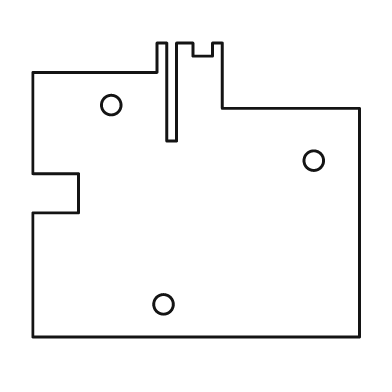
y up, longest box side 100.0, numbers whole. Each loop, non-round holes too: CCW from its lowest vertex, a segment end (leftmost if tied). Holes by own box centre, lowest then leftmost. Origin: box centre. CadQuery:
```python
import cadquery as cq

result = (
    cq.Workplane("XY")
    .moveTo(-50.0, -45.0)
    .lineTo(50.0, -45.0)
    .lineTo(50.0, 25.0)
    .lineTo(8.0, 25.0)
    .lineTo(8.0, 45.0)
    .lineTo(5.0, 45.0)
    .lineTo(5.0, 41.0)
    .lineTo(-1.0, 41.0)
    .lineTo(-1.0, 45.0)
    .lineTo(-6.0, 45.0)
    .lineTo(-6.0, 15.0)
    .lineTo(-9.0, 15.0)
    .lineTo(-9.0, 45.0)
    .lineTo(-12.0, 45.0)
    .lineTo(-12.0, 36.0)
    .lineTo(-50.0, 36.0)
    .lineTo(-50.0, 5.0)
    .lineTo(-36.0, 5.0)
    .lineTo(-36.0, -7.0)
    .lineTo(-50.0, -7.0)
    .close()
    .moveTo(-10.0, -35.0)
    .circle(3.0)
    .moveTo(36.0, 9.0)
    .circle(3.0)
    .moveTo(-26.0, 26.0)
    .circle(3.0)
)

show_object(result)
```